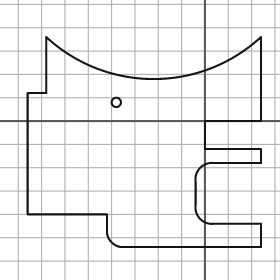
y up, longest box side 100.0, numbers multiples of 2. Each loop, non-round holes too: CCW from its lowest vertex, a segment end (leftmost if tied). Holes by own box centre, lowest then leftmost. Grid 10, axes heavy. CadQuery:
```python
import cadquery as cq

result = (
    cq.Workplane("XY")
    .moveTo(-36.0, -54.0)
    .lineTo(24.0, -54.0)
    .lineTo(24.0, -44.0)
    .lineTo(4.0, -44.0)
    .threePointArc((-2.0, -42.0), (-4.0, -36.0))
    .lineTo(-4.0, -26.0)
    .threePointArc((-2.0, -20.0), (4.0, -18.0))
    .lineTo(24.0, -18.0)
    .lineTo(24.0, -12.0)
    .lineTo(0.0, -12.0)
    .lineTo(0.0, 0.0)
    .lineTo(24.0, 0.0)
    .lineTo(24.0, 36.0)
    .threePointArc((-22.0, 18.0), (-68.0, 36.0))
    .lineTo(-68.0, 12.0)
    .lineTo(-76.0, 12.0)
    .lineTo(-76.0, -40.0)
    .lineTo(-42.0, -40.0)
    .lineTo(-42.0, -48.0)
    .threePointArc((-40.0, -52.0), (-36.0, -54.0))
    .close()
    .moveTo(-38.0, 8.0)
    .circle(2.0)
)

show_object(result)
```